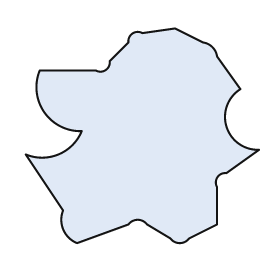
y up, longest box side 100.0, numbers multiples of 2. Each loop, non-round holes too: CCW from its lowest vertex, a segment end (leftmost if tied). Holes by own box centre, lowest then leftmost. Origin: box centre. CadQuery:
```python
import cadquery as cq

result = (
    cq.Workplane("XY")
    .moveTo(-28.0, -46.0)
    .lineTo(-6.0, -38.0)
    .threePointArc((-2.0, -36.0), (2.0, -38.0))
    .lineTo(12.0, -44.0)
    .threePointArc((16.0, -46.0), (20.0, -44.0))
    .lineTo(32.0, -38.0)
    .lineTo(32.0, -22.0)
    .threePointArc((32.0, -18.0), (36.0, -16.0))
    .lineTo(50.0, -6.0)
    .threePointArc((36.0, 4.0), (42.0, 20.0))
    .lineTo(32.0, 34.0)
    .threePointArc((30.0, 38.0), (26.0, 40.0))
    .lineTo(14.0, 46.0)
    .lineTo(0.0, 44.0)
    .threePointArc((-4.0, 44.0), (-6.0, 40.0))
    .lineTo(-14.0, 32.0)
    .threePointArc((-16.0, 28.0), (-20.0, 28.0))
    .lineTo(-44.0, 28.0)
    .threePointArc((-42.0, 10.0), (-26.0, 2.0))
    .threePointArc((-36.0, -8.0), (-50.0, -8.0))
    .lineTo(-34.0, -32.0)
    .threePointArc((-34.0, -40.0), (-28.0, -46.0))
    .close()
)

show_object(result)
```